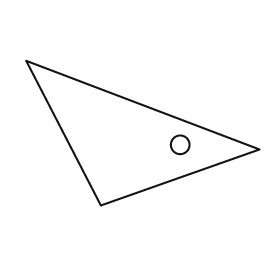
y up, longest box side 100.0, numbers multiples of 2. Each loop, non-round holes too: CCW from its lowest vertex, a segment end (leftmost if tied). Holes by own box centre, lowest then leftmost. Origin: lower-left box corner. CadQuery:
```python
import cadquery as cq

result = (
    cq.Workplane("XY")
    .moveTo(32.0, 0.0)
    .lineTo(100.0, 24.0)
    .lineTo(0.0, 62.0)
    .close()
    .moveTo(66.0, 26.0)
    .circle(4.0)
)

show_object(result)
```